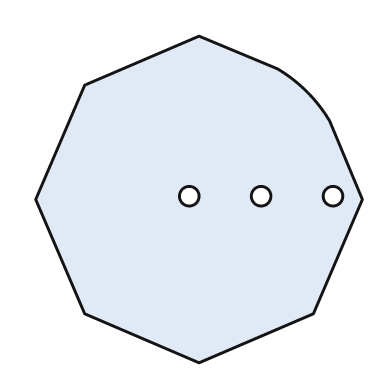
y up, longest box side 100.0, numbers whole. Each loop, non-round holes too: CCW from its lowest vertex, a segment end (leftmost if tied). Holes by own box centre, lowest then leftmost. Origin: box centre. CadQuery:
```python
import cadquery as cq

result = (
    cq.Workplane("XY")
    .moveTo(0.0, -50.0)
    .lineTo(35.0, -35.0)
    .lineTo(50.0, 0.0)
    .lineTo(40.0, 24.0)
    .threePointArc((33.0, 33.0), (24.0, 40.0))
    .lineTo(0.0, 50.0)
    .lineTo(-35.0, 35.0)
    .lineTo(-50.0, 0.0)
    .lineTo(-35.0, -35.0)
    .close()
    .moveTo(-3.0, 1.0)
    .circle(3.0)
    .moveTo(19.0, 1.0)
    .circle(3.0)
    .moveTo(41.0, 1.0)
    .circle(3.0)
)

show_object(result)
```